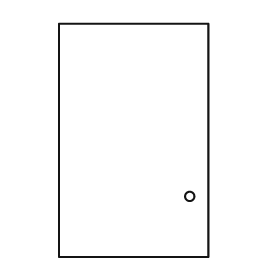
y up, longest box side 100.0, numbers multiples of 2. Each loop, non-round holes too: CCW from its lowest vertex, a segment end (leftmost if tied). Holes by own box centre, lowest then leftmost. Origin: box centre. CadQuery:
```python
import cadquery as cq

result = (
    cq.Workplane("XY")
    .moveTo(-32.0, -50.0)
    .lineTo(32.0, -50.0)
    .lineTo(32.0, 50.0)
    .lineTo(-32.0, 50.0)
    .close()
    .moveTo(24.0, -24.0)
    .circle(2.0)
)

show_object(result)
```